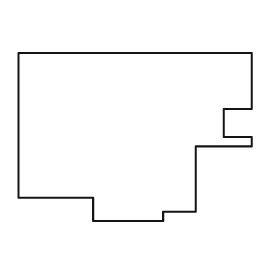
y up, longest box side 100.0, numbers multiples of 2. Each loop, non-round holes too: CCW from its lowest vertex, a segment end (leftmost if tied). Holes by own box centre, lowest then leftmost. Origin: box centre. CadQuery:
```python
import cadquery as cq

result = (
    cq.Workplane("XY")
    .moveTo(-18.0, -36.0)
    .lineTo(12.0, -36.0)
    .lineTo(12.0, -32.0)
    .lineTo(26.0, -32.0)
    .lineTo(26.0, -4.0)
    .lineTo(50.0, -4.0)
    .lineTo(50.0, 0.0)
    .lineTo(38.0, 0.0)
    .lineTo(38.0, 12.0)
    .lineTo(50.0, 12.0)
    .lineTo(50.0, 36.0)
    .lineTo(-50.0, 36.0)
    .lineTo(-50.0, -26.0)
    .lineTo(-18.0, -26.0)
    .close()
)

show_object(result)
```